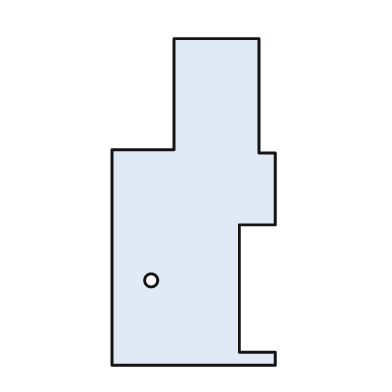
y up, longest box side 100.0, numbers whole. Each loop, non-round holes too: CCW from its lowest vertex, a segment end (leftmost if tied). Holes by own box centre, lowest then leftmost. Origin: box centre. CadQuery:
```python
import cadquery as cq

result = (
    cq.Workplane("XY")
    .moveTo(-25.0, -50.0)
    .lineTo(25.0, -50.0)
    .lineTo(25.0, -46.0)
    .lineTo(14.0, -46.0)
    .lineTo(14.0, -7.0)
    .lineTo(25.0, -7.0)
    .lineTo(25.0, 15.0)
    .lineTo(20.0, 15.0)
    .lineTo(20.0, 50.0)
    .lineTo(-6.0, 50.0)
    .lineTo(-6.0, 16.0)
    .lineTo(-25.0, 16.0)
    .close()
    .moveTo(-13.0, -24.0)
    .circle(2.0)
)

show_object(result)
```